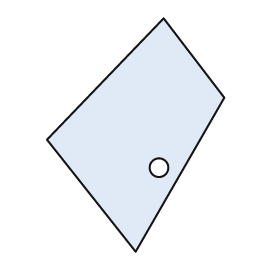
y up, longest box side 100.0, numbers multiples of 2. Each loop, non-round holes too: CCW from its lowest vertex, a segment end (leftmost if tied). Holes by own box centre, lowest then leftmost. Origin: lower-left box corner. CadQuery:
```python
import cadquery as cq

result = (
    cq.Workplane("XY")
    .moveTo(38.0, 0.0)
    .lineTo(76.0, 66.0)
    .lineTo(50.0, 100.0)
    .lineTo(0.0, 48.0)
    .close()
    .moveTo(48.0, 36.0)
    .circle(4.0)
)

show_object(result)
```